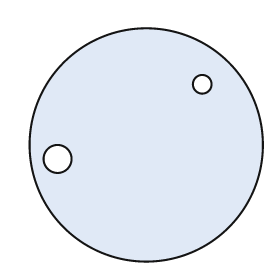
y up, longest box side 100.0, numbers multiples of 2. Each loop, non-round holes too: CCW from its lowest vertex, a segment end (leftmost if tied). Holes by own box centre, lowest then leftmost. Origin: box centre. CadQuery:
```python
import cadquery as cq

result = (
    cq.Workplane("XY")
    .moveTo(0.0, 0.0)
    .circle(50.0)
    .moveTo(-38.0, -6.0)
    .circle(6.0)
    .moveTo(24.0, 26.0)
    .circle(4.0)
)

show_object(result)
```